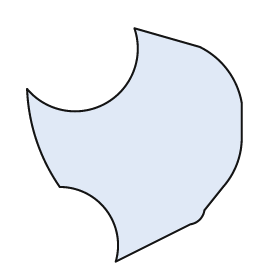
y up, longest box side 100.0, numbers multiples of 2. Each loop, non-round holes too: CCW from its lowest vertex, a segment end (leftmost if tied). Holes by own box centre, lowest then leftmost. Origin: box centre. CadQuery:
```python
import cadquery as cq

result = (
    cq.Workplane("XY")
    .moveTo(-8.0, -50.0)
    .lineTo(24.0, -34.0)
    .threePointArc((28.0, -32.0), (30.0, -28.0))
    .lineTo(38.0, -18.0)
    .threePointArc((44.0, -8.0), (46.0, 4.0))
    .lineTo(46.0, 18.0)
    .threePointArc((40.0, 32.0), (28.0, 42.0))
    .lineTo(0.0, 50.0)
    .threePointArc((-12.0, 18.0), (-46.0, 24.0))
    .threePointArc((-42.0, 2.0), (-32.0, -18.0))
    .threePointArc((-12.0, -28.0), (-8.0, -50.0))
    .close()
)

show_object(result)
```